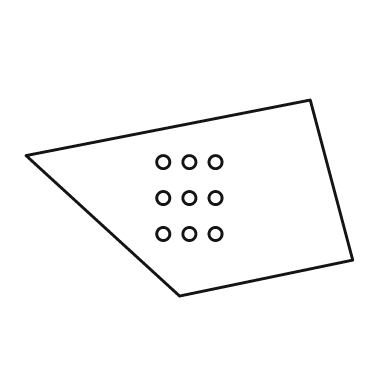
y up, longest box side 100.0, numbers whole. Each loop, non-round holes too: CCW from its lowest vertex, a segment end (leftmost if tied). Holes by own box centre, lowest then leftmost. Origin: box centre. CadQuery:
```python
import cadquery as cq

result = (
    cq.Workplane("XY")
    .moveTo(-3.0, -30.0)
    .lineTo(50.0, -19.0)
    .lineTo(37.0, 30.0)
    .lineTo(-50.0, 13.0)
    .close()
    .moveTo(-8.0, -11.0)
    .circle(2.0)
    .moveTo(0.0, -11.0)
    .circle(2.0)
    .moveTo(8.0, -11.0)
    .circle(2.0)
    .moveTo(-8.0, 0.0)
    .circle(2.0)
    .moveTo(0.0, 0.0)
    .circle(2.0)
    .moveTo(8.0, 0.0)
    .circle(2.0)
    .moveTo(-8.0, 11.0)
    .circle(2.0)
    .moveTo(0.0, 11.0)
    .circle(2.0)
    .moveTo(8.0, 11.0)
    .circle(2.0)
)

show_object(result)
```